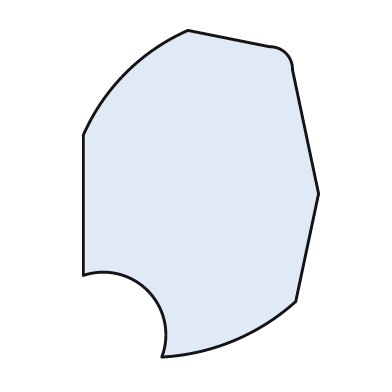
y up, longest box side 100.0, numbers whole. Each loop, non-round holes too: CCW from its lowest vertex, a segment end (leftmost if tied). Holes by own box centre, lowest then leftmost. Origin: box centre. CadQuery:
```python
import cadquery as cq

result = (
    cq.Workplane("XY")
    .moveTo(-12.0, -50.0)
    .threePointArc((10.0, -45.0), (29.0, -33.0))
    .lineTo(36.0, 0.0)
    .lineTo(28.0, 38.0)
    .threePointArc((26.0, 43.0), (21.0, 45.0))
    .lineTo(-4.0, 50.0)
    .threePointArc((-23.0, 37.0), (-36.0, 18.0))
    .lineTo(-36.0, -25.0)
    .threePointArc((-16.0, -30.0), (-12.0, -50.0))
    .close()
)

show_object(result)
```